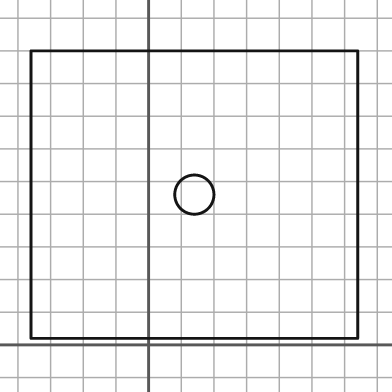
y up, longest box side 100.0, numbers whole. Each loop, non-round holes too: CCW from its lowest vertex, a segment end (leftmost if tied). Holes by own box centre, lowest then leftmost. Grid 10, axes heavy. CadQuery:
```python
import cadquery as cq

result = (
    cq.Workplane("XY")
    .moveTo(-36.0, 2.0)
    .lineTo(64.0, 2.0)
    .lineTo(64.0, 90.0)
    .lineTo(-36.0, 90.0)
    .close()
    .moveTo(14.0, 46.0)
    .circle(6.0)
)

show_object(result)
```